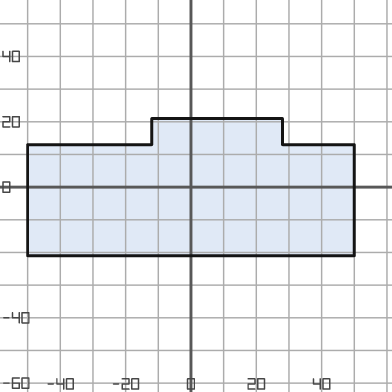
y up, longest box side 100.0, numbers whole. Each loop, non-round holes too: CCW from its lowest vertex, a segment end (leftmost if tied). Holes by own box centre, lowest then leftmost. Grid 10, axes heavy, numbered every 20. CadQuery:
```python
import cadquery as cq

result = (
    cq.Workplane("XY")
    .moveTo(-50.0, -21.0)
    .lineTo(50.0, -21.0)
    .lineTo(50.0, 13.0)
    .lineTo(28.0, 13.0)
    .lineTo(28.0, 21.0)
    .lineTo(-12.0, 21.0)
    .lineTo(-12.0, 13.0)
    .lineTo(-50.0, 13.0)
    .close()
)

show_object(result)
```